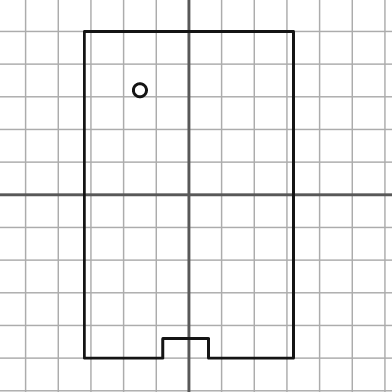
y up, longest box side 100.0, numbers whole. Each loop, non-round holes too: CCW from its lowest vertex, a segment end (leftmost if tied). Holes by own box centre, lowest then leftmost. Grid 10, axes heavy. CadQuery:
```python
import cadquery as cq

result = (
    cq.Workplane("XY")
    .moveTo(-32.0, -50.0)
    .lineTo(-8.0, -50.0)
    .lineTo(-8.0, -44.0)
    .lineTo(6.0, -44.0)
    .lineTo(6.0, -50.0)
    .lineTo(32.0, -50.0)
    .lineTo(32.0, 50.0)
    .lineTo(-32.0, 50.0)
    .close()
    .moveTo(-15.0, 32.0)
    .circle(2.0)
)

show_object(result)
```